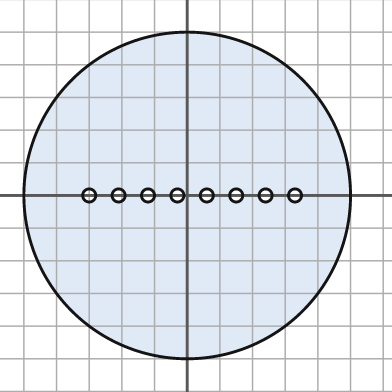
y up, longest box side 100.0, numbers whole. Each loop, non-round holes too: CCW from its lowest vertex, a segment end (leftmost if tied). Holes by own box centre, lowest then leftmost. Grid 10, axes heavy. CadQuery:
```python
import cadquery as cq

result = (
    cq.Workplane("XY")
    .moveTo(0.0, 0.0)
    .circle(50.0)
    .moveTo(-30.0, 0.0)
    .circle(2.0)
    .moveTo(-21.0, 0.0)
    .circle(2.0)
    .moveTo(-12.0, 0.0)
    .circle(2.0)
    .moveTo(-3.0, 0.0)
    .circle(2.0)
    .moveTo(6.0, 0.0)
    .circle(2.0)
    .moveTo(15.0, 0.0)
    .circle(2.0)
    .moveTo(24.0, 0.0)
    .circle(2.0)
    .moveTo(33.0, 0.0)
    .circle(2.0)
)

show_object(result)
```